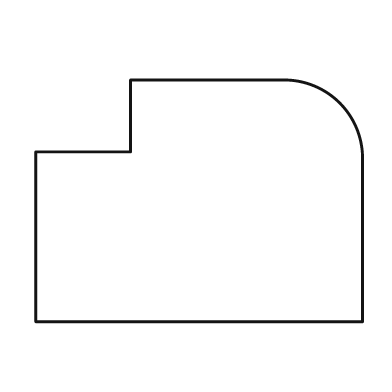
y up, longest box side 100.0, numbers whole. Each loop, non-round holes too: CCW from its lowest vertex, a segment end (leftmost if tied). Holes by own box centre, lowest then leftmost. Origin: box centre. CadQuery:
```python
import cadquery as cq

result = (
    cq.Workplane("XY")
    .moveTo(-50.0, -37.0)
    .lineTo(50.0, -37.0)
    .lineTo(50.0, 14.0)
    .threePointArc((43.0, 30.0), (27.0, 37.0))
    .lineTo(-21.0, 37.0)
    .lineTo(-21.0, 15.0)
    .lineTo(-50.0, 15.0)
    .close()
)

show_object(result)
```